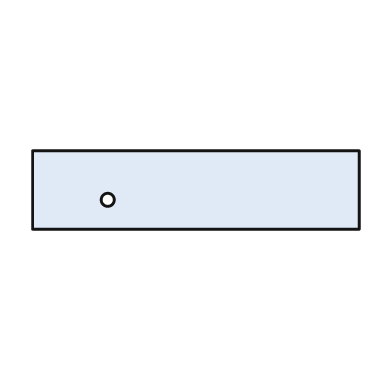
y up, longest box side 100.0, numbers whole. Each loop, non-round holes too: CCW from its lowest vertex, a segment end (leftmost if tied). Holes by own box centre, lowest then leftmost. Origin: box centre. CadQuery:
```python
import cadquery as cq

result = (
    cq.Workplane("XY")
    .moveTo(-50.0, -12.0)
    .lineTo(50.0, -12.0)
    .lineTo(50.0, 12.0)
    .lineTo(-50.0, 12.0)
    .close()
    .moveTo(-27.0, -3.0)
    .circle(2.0)
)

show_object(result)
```